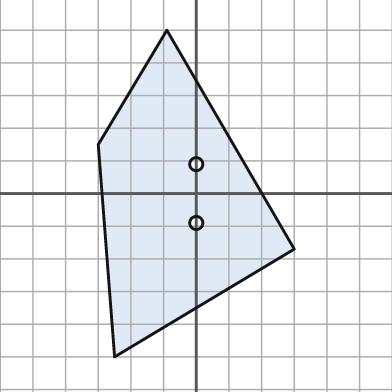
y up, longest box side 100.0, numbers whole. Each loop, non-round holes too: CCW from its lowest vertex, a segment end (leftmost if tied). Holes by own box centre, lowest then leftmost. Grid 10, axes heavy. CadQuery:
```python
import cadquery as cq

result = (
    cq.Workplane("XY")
    .moveTo(-25.0, -50.0)
    .lineTo(30.0, -17.0)
    .lineTo(-9.0, 50.0)
    .lineTo(-30.0, 15.0)
    .close()
    .moveTo(0.0, -9.0)
    .circle(2.0)
    .moveTo(0.0, 9.0)
    .circle(2.0)
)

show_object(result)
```